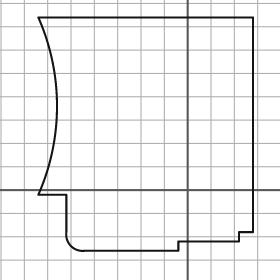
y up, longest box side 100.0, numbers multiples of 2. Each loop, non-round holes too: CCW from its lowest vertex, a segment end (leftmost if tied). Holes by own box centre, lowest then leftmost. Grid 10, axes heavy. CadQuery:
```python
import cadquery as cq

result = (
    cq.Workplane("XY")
    .moveTo(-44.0, -26.0)
    .lineTo(-4.0, -26.0)
    .lineTo(-4.0, -22.0)
    .lineTo(22.0, -22.0)
    .lineTo(22.0, -18.0)
    .lineTo(28.0, -18.0)
    .lineTo(28.0, 74.0)
    .lineTo(-64.0, 74.0)
    .threePointArc((-56.0, 36.0), (-64.0, -2.0))
    .lineTo(-52.0, -2.0)
    .lineTo(-52.0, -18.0)
    .threePointArc((-50.0, -24.0), (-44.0, -26.0))
    .close()
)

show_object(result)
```